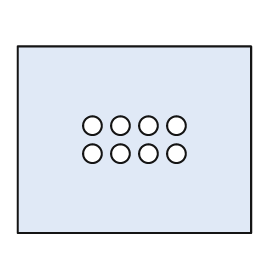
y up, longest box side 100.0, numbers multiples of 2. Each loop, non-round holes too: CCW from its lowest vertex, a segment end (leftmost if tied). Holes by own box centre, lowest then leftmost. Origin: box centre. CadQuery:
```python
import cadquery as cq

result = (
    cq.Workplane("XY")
    .moveTo(-50.0, -40.0)
    .lineTo(50.0, -40.0)
    .lineTo(50.0, 40.0)
    .lineTo(-50.0, 40.0)
    .close()
    .moveTo(-18.0, -6.0)
    .circle(4.0)
    .moveTo(-6.0, -6.0)
    .circle(4.0)
    .moveTo(6.0, -6.0)
    .circle(4.0)
    .moveTo(18.0, -6.0)
    .circle(4.0)
    .moveTo(-18.0, 6.0)
    .circle(4.0)
    .moveTo(-6.0, 6.0)
    .circle(4.0)
    .moveTo(6.0, 6.0)
    .circle(4.0)
    .moveTo(18.0, 6.0)
    .circle(4.0)
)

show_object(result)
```